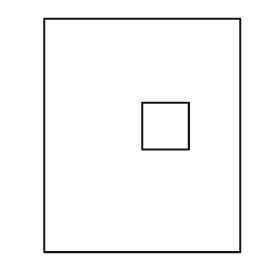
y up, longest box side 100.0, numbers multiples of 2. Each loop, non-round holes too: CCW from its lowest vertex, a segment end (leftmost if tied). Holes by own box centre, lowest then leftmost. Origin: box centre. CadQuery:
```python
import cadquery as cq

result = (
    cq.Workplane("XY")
    .moveTo(-42.0, -50.0)
    .lineTo(42.0, -50.0)
    .lineTo(42.0, 50.0)
    .lineTo(-42.0, 50.0)
    .close()
    .moveTo(0.0, -6.0)
    .lineTo(20.0, -6.0)
    .lineTo(20.0, 14.0)
    .lineTo(0.0, 14.0)
    .close()
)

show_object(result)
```